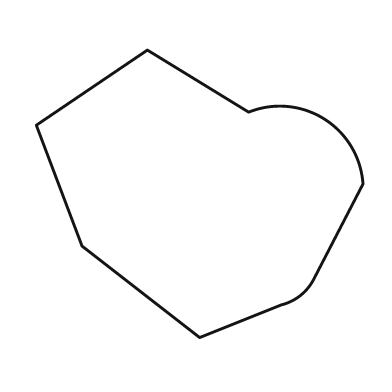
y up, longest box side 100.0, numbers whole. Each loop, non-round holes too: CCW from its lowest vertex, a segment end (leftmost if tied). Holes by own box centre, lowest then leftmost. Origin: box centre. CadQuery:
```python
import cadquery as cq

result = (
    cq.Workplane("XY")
    .moveTo(0.0, -44.0)
    .lineTo(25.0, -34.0)
    .threePointArc((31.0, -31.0), (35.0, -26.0))
    .lineTo(50.0, 3.0)
    .threePointArc((38.0, 23.0), (15.0, 25.0))
    .lineTo(-16.0, 44.0)
    .lineTo(-50.0, 21.0)
    .lineTo(-36.0, -16.0)
    .close()
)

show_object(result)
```